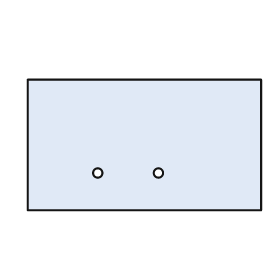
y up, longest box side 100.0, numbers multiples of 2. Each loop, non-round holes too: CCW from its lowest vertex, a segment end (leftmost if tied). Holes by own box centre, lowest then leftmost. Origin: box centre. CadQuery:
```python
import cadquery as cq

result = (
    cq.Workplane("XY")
    .moveTo(-50.0, -28.0)
    .lineTo(50.0, -28.0)
    .lineTo(50.0, 28.0)
    .lineTo(-50.0, 28.0)
    .close()
    .moveTo(-20.0, -12.0)
    .circle(2.0)
    .moveTo(6.0, -12.0)
    .circle(2.0)
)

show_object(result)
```